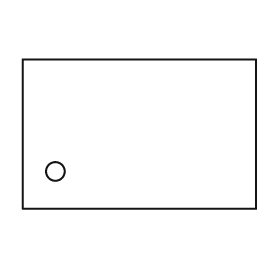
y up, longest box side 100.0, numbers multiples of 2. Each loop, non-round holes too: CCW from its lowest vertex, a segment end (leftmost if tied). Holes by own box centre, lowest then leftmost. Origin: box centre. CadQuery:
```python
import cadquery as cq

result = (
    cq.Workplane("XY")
    .moveTo(-50.0, -32.0)
    .lineTo(50.0, -32.0)
    .lineTo(50.0, 32.0)
    .lineTo(-50.0, 32.0)
    .close()
    .moveTo(-36.0, -16.0)
    .circle(4.0)
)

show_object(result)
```